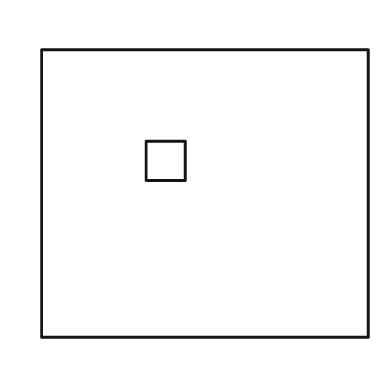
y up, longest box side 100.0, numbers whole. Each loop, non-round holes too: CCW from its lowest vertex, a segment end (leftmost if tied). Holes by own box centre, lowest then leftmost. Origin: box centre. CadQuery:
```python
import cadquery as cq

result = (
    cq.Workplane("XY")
    .moveTo(-50.0, -44.0)
    .lineTo(50.0, -44.0)
    .lineTo(50.0, 44.0)
    .lineTo(-50.0, 44.0)
    .close()
    .moveTo(-18.0, 4.0)
    .lineTo(-6.0, 4.0)
    .lineTo(-6.0, 16.0)
    .lineTo(-18.0, 16.0)
    .close()
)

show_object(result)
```